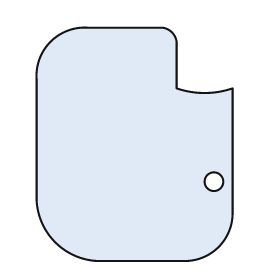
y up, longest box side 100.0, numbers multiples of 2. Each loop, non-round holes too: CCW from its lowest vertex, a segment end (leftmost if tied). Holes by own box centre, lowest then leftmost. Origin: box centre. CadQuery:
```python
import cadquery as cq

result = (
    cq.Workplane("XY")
    .moveTo(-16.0, -50.0)
    .lineTo(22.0, -50.0)
    .threePointArc((36.0, -44.0), (42.0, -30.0))
    .lineTo(42.0, 24.0)
    .threePointArc((30.0, 22.0), (18.0, 24.0))
    .lineTo(18.0, 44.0)
    .threePointArc((16.0, 48.0), (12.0, 50.0))
    .lineTo(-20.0, 50.0)
    .threePointArc((-36.0, 44.0), (-42.0, 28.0))
    .lineTo(-42.0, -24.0)
    .threePointArc((-34.0, -42.0), (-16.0, -50.0))
    .close()
    .moveTo(34.0, -16.0)
    .circle(4.0)
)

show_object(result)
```